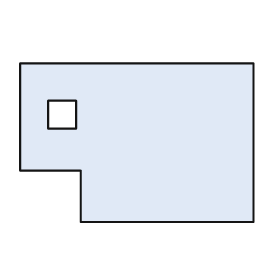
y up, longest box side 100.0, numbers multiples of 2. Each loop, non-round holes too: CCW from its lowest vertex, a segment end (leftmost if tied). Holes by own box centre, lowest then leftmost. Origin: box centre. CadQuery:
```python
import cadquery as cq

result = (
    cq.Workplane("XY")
    .moveTo(-24.0, -34.0)
    .lineTo(50.0, -34.0)
    .lineTo(50.0, 34.0)
    .lineTo(-50.0, 34.0)
    .lineTo(-50.0, -12.0)
    .lineTo(-24.0, -12.0)
    .close()
    .moveTo(-38.0, 6.0)
    .lineTo(-26.0, 6.0)
    .lineTo(-26.0, 18.0)
    .lineTo(-38.0, 18.0)
    .close()
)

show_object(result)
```